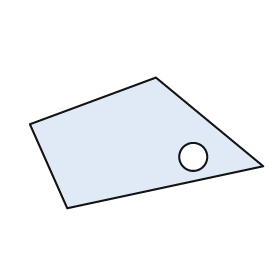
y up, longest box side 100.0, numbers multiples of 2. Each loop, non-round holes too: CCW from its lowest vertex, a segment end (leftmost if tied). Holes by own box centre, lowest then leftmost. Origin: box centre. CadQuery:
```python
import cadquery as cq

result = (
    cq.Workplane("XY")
    .moveTo(-34.0, -28.0)
    .lineTo(50.0, -10.0)
    .lineTo(4.0, 28.0)
    .lineTo(-50.0, 8.0)
    .close()
    .moveTo(20.0, -6.0)
    .circle(6.0)
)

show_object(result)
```